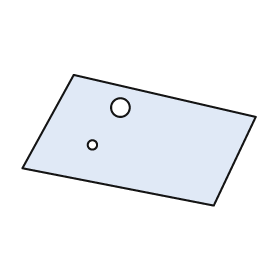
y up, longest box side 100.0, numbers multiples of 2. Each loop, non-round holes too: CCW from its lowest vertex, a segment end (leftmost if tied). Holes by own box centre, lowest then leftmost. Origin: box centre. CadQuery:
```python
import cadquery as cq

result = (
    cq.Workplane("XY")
    .moveTo(32.0, -28.0)
    .lineTo(50.0, 10.0)
    .lineTo(-28.0, 28.0)
    .lineTo(-50.0, -12.0)
    .close()
    .moveTo(-20.0, -2.0)
    .circle(2.0)
    .moveTo(-8.0, 14.0)
    .circle(4.0)
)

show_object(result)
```